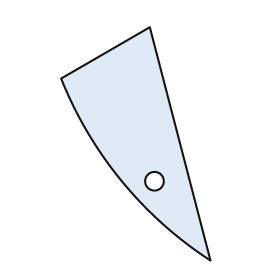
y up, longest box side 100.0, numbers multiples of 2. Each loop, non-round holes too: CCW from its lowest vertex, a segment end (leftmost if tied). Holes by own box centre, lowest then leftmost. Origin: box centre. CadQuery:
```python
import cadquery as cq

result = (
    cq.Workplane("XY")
    .moveTo(32.0, -50.0)
    .lineTo(6.0, 50.0)
    .lineTo(-32.0, 28.0)
    .threePointArc((-6.0, -16.0), (32.0, -50.0))
    .close()
    .moveTo(8.0, -16.0)
    .circle(4.0)
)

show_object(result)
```